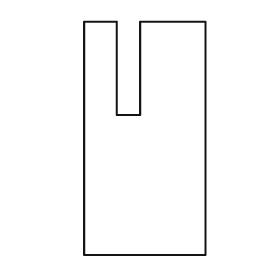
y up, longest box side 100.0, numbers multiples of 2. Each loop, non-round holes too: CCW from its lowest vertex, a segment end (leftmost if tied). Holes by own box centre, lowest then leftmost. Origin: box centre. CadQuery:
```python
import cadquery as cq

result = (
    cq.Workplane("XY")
    .moveTo(-26.0, -50.0)
    .lineTo(26.0, -50.0)
    .lineTo(26.0, 50.0)
    .lineTo(-2.0, 50.0)
    .lineTo(-2.0, 10.0)
    .lineTo(-12.0, 10.0)
    .lineTo(-12.0, 50.0)
    .lineTo(-26.0, 50.0)
    .close()
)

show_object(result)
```